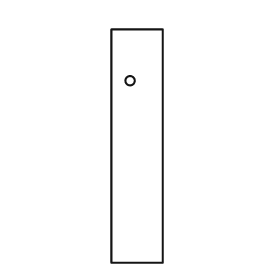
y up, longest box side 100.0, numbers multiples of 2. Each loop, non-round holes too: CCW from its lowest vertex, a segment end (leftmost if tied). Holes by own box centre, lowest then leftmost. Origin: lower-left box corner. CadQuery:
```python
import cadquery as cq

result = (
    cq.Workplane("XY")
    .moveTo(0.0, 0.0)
    .lineTo(22.0, 0.0)
    .lineTo(22.0, 100.0)
    .lineTo(0.0, 100.0)
    .close()
    .moveTo(8.0, 78.0)
    .circle(2.0)
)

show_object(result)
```